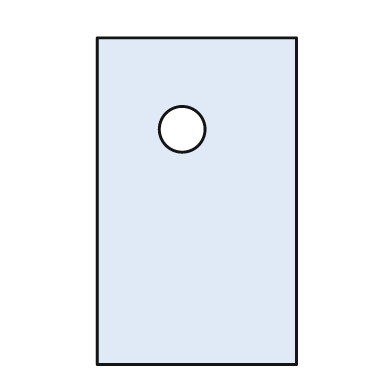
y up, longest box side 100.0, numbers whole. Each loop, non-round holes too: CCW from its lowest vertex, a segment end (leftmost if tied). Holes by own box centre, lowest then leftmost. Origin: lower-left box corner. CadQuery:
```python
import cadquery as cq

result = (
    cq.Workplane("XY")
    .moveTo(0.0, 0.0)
    .lineTo(61.0, 0.0)
    .lineTo(61.0, 100.0)
    .lineTo(0.0, 100.0)
    .close()
    .moveTo(26.0, 72.0)
    .circle(7.0)
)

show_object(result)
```